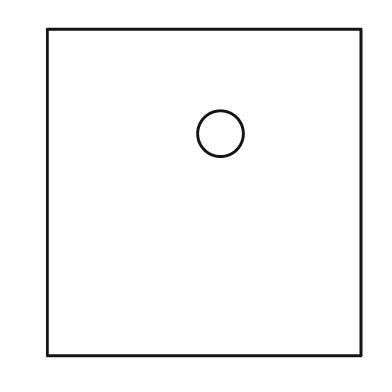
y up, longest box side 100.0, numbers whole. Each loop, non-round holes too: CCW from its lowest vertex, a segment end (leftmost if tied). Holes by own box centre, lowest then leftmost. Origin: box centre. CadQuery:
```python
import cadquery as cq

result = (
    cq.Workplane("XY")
    .moveTo(-48.0, -50.0)
    .lineTo(48.0, -50.0)
    .lineTo(48.0, 50.0)
    .lineTo(-48.0, 50.0)
    .close()
    .moveTo(5.0, 18.0)
    .circle(7.0)
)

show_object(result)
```